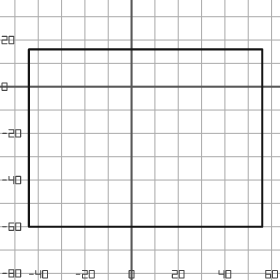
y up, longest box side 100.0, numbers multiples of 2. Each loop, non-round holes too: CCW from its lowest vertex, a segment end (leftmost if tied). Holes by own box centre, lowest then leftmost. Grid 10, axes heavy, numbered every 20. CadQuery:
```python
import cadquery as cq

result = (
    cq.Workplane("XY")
    .moveTo(-44.0, -60.0)
    .lineTo(56.0, -60.0)
    .lineTo(56.0, 16.0)
    .lineTo(-44.0, 16.0)
    .close()
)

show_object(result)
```